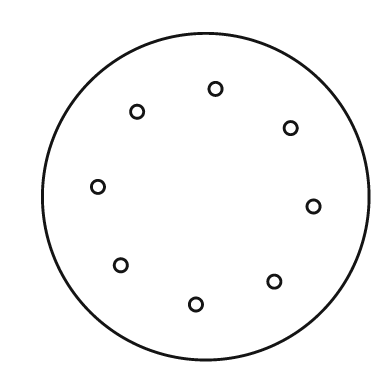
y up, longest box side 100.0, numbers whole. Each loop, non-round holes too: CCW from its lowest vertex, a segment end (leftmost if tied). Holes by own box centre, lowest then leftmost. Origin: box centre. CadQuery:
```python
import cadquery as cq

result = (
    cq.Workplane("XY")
    .moveTo(0.0, 0.0)
    .circle(50.0)
    .moveTo(-3.0, -33.0)
    .circle(2.0)
    .moveTo(21.0, -26.0)
    .circle(2.0)
    .moveTo(-26.0, -21.0)
    .circle(2.0)
    .moveTo(33.0, -3.0)
    .circle(2.0)
    .moveTo(-33.0, 3.0)
    .circle(2.0)
    .moveTo(26.0, 21.0)
    .circle(2.0)
    .moveTo(-21.0, 26.0)
    .circle(2.0)
    .moveTo(3.0, 33.0)
    .circle(2.0)
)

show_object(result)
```